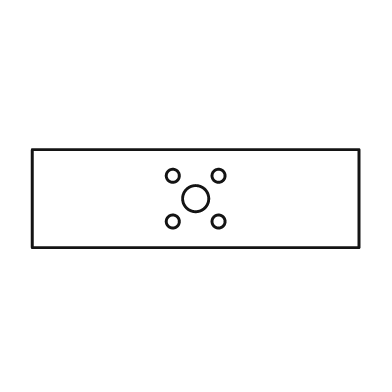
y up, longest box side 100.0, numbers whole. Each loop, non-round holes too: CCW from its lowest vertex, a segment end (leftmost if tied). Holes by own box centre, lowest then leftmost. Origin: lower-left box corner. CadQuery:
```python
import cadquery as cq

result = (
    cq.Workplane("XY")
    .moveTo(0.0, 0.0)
    .lineTo(100.0, 0.0)
    .lineTo(100.0, 30.0)
    .lineTo(0.0, 30.0)
    .close()
    .moveTo(43.0, 8.0)
    .circle(2.0)
    .moveTo(57.0, 8.0)
    .circle(2.0)
    .moveTo(50.0, 15.0)
    .circle(4.0)
    .moveTo(43.0, 22.0)
    .circle(2.0)
    .moveTo(57.0, 22.0)
    .circle(2.0)
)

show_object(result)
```